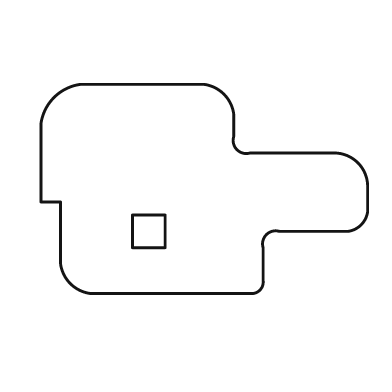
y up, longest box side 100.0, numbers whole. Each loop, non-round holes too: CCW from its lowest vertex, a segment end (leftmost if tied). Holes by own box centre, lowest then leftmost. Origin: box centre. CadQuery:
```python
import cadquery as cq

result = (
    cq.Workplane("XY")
    .moveTo(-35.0, -32.0)
    .lineTo(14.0, -32.0)
    .threePointArc((17.0, -31.0), (18.0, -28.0))
    .lineTo(18.0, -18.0)
    .threePointArc((19.0, -14.0), (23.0, -13.0))
    .lineTo(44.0, -13.0)
    .threePointArc((48.0, -11.0), (50.0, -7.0))
    .lineTo(50.0, 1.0)
    .threePointArc((47.0, 8.0), (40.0, 11.0))
    .lineTo(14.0, 11.0)
    .threePointArc((10.0, 12.0), (9.0, 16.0))
    .lineTo(9.0, 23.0)
    .threePointArc((6.0, 29.0), (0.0, 32.0))
    .lineTo(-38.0, 32.0)
    .threePointArc((-46.0, 28.0), (-50.0, 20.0))
    .lineTo(-50.0, -4.0)
    .lineTo(-44.0, -4.0)
    .lineTo(-44.0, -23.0)
    .threePointArc((-41.0, -29.0), (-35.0, -32.0))
    .close()
    .moveTo(-22.0, -18.0)
    .lineTo(-12.0, -18.0)
    .lineTo(-12.0, -8.0)
    .lineTo(-22.0, -8.0)
    .close()
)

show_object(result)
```